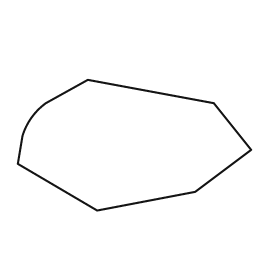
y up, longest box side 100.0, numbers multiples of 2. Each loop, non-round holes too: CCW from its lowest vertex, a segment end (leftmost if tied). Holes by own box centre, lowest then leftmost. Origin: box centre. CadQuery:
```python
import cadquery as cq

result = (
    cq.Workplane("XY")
    .moveTo(-16.0, -28.0)
    .lineTo(26.0, -20.0)
    .lineTo(50.0, -2.0)
    .lineTo(34.0, 18.0)
    .lineTo(-20.0, 28.0)
    .lineTo(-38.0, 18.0)
    .threePointArc((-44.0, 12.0), (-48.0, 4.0))
    .lineTo(-50.0, -8.0)
    .close()
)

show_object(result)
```